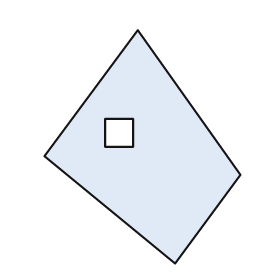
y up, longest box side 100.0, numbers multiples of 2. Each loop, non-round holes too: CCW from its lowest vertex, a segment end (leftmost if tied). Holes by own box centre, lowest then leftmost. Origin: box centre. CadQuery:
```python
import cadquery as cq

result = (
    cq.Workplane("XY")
    .moveTo(14.0, -50.0)
    .lineTo(42.0, -12.0)
    .lineTo(-2.0, 50.0)
    .lineTo(-42.0, -4.0)
    .close()
    .moveTo(-16.0, 0.0)
    .lineTo(-4.0, 0.0)
    .lineTo(-4.0, 12.0)
    .lineTo(-16.0, 12.0)
    .close()
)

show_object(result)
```